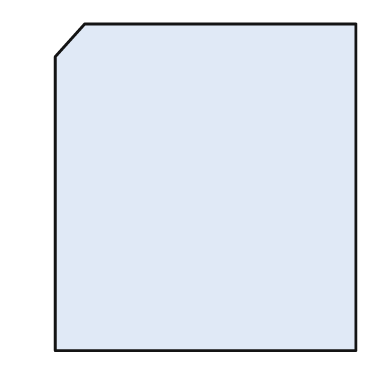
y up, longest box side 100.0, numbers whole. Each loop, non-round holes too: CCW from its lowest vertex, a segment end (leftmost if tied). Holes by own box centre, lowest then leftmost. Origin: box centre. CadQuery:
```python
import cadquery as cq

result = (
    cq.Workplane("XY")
    .moveTo(-46.0, -50.0)
    .lineTo(46.0, -50.0)
    .lineTo(46.0, 50.0)
    .lineTo(-37.0, 50.0)
    .lineTo(-46.0, 40.0)
    .close()
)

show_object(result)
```